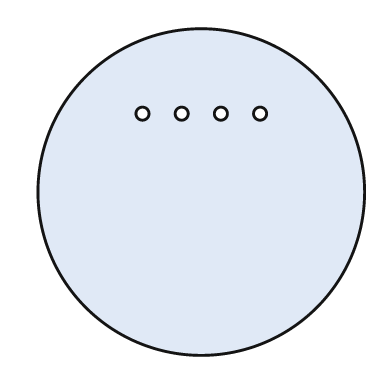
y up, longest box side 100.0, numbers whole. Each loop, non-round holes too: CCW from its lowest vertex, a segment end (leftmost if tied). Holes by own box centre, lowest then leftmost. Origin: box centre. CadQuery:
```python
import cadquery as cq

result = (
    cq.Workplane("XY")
    .moveTo(0.0, 0.0)
    .circle(50.0)
    .moveTo(-18.0, 24.0)
    .circle(2.0)
    .moveTo(-6.0, 24.0)
    .circle(2.0)
    .moveTo(6.0, 24.0)
    .circle(2.0)
    .moveTo(18.0, 24.0)
    .circle(2.0)
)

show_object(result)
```